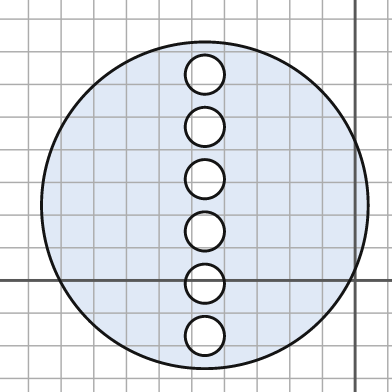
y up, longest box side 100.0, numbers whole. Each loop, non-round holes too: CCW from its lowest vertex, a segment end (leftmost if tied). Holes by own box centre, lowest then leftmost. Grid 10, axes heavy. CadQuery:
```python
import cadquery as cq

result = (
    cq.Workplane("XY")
    .moveTo(-46.0, 23.0)
    .circle(50.0)
    .moveTo(-46.0, -17.0)
    .circle(6.0)
    .moveTo(-46.0, -1.0)
    .circle(6.0)
    .moveTo(-46.0, 15.0)
    .circle(6.0)
    .moveTo(-46.0, 31.0)
    .circle(6.0)
    .moveTo(-46.0, 47.0)
    .circle(6.0)
    .moveTo(-46.0, 63.0)
    .circle(6.0)
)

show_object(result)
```